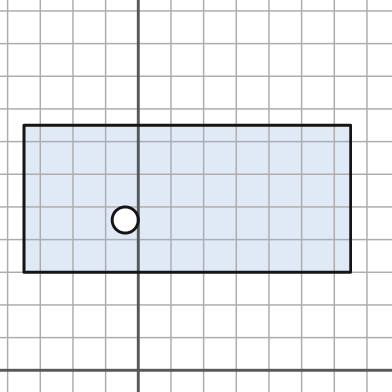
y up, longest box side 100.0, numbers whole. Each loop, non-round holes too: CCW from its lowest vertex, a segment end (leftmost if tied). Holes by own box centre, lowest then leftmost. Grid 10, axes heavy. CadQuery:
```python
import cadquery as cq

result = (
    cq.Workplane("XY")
    .moveTo(-35.0, 30.0)
    .lineTo(65.0, 30.0)
    .lineTo(65.0, 75.0)
    .lineTo(-35.0, 75.0)
    .close()
    .moveTo(-4.0, 46.0)
    .circle(4.0)
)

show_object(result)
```